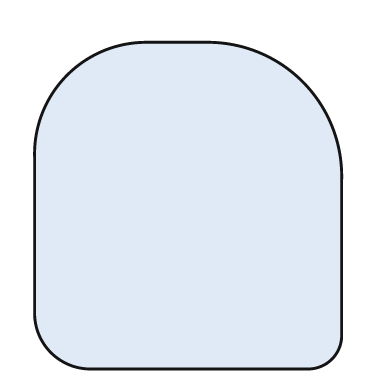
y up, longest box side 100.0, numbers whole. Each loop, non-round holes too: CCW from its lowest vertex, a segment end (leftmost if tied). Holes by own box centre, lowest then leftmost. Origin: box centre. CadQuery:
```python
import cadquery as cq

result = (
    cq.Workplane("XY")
    .moveTo(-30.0, -50.0)
    .lineTo(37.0, -50.0)
    .threePointArc((44.0, -47.0), (47.0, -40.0))
    .lineTo(47.0, 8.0)
    .threePointArc((35.0, 38.0), (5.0, 50.0))
    .lineTo(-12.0, 50.0)
    .threePointArc((-37.0, 40.0), (-47.0, 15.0))
    .lineTo(-47.0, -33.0)
    .threePointArc((-42.0, -45.0), (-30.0, -50.0))
    .close()
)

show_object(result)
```